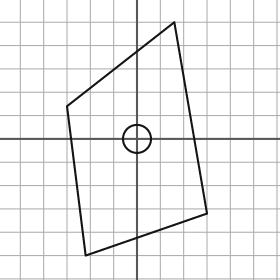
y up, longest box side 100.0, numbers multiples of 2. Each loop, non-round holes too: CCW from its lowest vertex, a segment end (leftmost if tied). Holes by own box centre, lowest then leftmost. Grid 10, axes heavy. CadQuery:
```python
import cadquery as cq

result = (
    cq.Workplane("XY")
    .moveTo(-22.0, -50.0)
    .lineTo(30.0, -32.0)
    .lineTo(16.0, 50.0)
    .lineTo(-30.0, 14.0)
    .close()
    .moveTo(0.0, 0.0)
    .circle(6.0)
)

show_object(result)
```